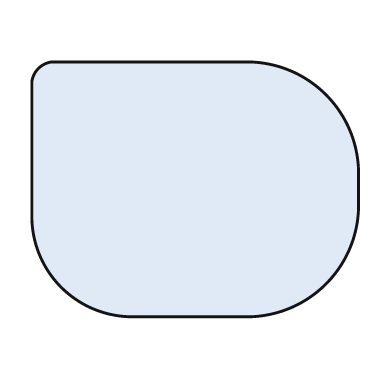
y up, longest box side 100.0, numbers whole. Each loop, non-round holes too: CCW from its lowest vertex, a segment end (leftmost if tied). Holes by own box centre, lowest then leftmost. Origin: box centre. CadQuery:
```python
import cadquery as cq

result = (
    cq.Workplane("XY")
    .moveTo(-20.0, -39.0)
    .lineTo(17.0, -39.0)
    .threePointArc((40.0, -29.0), (50.0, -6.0))
    .lineTo(50.0, 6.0)
    .threePointArc((40.0, 29.0), (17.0, 39.0))
    .lineTo(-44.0, 39.0)
    .threePointArc((-48.0, 37.0), (-50.0, 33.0))
    .lineTo(-50.0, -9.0)
    .threePointArc((-41.0, -30.0), (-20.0, -39.0))
    .close()
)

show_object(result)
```